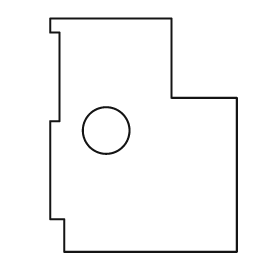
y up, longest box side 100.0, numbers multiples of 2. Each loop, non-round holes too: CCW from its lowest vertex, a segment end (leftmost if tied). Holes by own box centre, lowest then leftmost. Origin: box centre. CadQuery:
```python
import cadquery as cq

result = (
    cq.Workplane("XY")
    .moveTo(-34.0, -50.0)
    .lineTo(40.0, -50.0)
    .lineTo(40.0, 16.0)
    .lineTo(12.0, 16.0)
    .lineTo(12.0, 50.0)
    .lineTo(-40.0, 50.0)
    .lineTo(-40.0, 44.0)
    .lineTo(-36.0, 44.0)
    .lineTo(-36.0, 6.0)
    .lineTo(-40.0, 6.0)
    .lineTo(-40.0, -36.0)
    .lineTo(-34.0, -36.0)
    .close()
    .moveTo(-16.0, 2.0)
    .circle(10.0)
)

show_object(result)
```